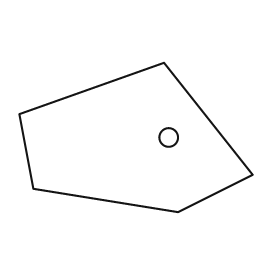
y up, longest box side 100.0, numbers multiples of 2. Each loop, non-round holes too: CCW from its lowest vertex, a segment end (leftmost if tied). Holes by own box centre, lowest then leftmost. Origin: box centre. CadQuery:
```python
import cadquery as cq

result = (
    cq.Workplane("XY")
    .moveTo(18.0, -32.0)
    .lineTo(50.0, -16.0)
    .lineTo(12.0, 32.0)
    .lineTo(-50.0, 10.0)
    .lineTo(-44.0, -22.0)
    .close()
    .moveTo(14.0, 0.0)
    .circle(4.0)
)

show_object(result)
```